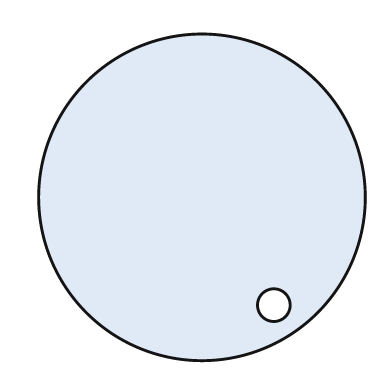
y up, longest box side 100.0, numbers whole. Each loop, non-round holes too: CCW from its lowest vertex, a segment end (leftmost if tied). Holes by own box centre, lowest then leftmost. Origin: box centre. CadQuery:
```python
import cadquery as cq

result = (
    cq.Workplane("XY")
    .moveTo(0.0, 0.0)
    .circle(50.0)
    .moveTo(22.0, -33.0)
    .circle(5.0)
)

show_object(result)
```